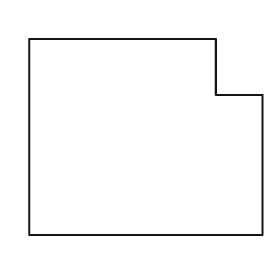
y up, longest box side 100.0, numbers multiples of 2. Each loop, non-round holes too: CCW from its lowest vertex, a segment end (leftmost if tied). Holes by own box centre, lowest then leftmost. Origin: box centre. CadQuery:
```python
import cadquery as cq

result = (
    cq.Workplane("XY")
    .moveTo(-50.0, -42.0)
    .lineTo(50.0, -42.0)
    .lineTo(50.0, 18.0)
    .lineTo(30.0, 18.0)
    .lineTo(30.0, 42.0)
    .lineTo(-50.0, 42.0)
    .close()
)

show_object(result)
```